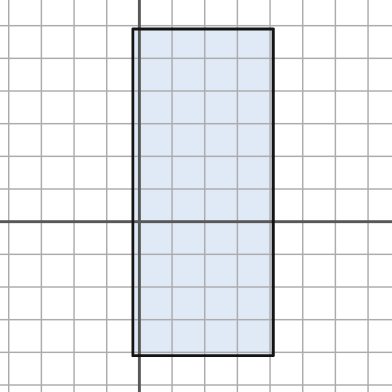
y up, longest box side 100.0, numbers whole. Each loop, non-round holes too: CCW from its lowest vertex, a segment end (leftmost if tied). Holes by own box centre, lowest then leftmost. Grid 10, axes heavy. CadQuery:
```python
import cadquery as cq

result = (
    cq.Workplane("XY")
    .moveTo(-2.0, -41.0)
    .lineTo(41.0, -41.0)
    .lineTo(41.0, 59.0)
    .lineTo(-2.0, 59.0)
    .close()
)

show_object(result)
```